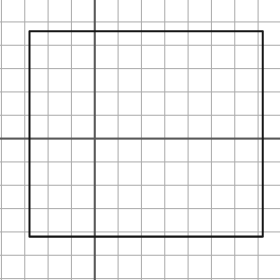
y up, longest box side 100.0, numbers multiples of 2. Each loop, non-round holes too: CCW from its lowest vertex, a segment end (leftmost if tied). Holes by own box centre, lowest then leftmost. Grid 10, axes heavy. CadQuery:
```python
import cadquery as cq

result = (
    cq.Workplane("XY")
    .moveTo(-28.0, -42.0)
    .lineTo(72.0, -42.0)
    .lineTo(72.0, 46.0)
    .lineTo(-28.0, 46.0)
    .close()
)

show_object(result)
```